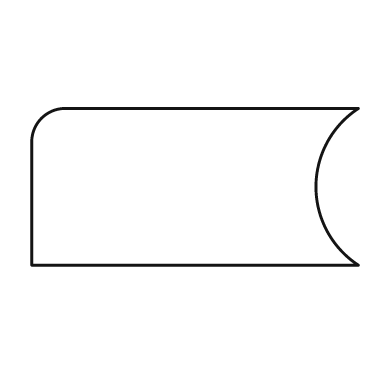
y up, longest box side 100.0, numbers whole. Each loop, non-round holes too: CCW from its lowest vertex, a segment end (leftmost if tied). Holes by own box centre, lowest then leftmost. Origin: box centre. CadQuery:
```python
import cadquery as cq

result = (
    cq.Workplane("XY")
    .moveTo(-50.0, -24.0)
    .lineTo(50.0, -24.0)
    .threePointArc((37.0, 0.0), (50.0, 24.0))
    .lineTo(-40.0, 24.0)
    .threePointArc((-47.0, 21.0), (-50.0, 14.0))
    .close()
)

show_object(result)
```